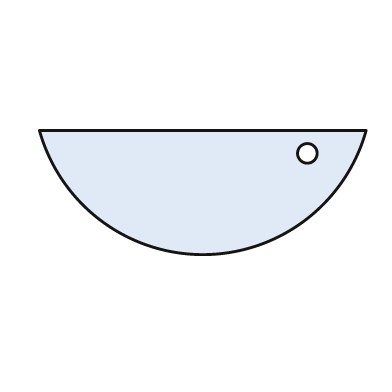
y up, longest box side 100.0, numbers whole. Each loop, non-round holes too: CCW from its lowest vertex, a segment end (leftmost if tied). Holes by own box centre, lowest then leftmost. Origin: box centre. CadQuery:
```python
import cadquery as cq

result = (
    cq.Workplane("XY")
    .moveTo(-50.0, 19.0)
    .threePointArc((0.0, -19.0), (50.0, 19.0))
    .close()
    .moveTo(32.0, 12.0)
    .circle(3.0)
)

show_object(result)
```